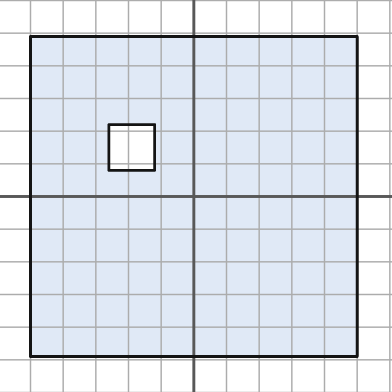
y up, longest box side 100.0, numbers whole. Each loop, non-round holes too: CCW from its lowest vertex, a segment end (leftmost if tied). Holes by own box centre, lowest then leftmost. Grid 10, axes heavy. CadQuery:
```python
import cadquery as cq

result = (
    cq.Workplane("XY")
    .moveTo(-50.0, -49.0)
    .lineTo(50.0, -49.0)
    .lineTo(50.0, 49.0)
    .lineTo(-50.0, 49.0)
    .close()
    .moveTo(-26.0, 8.0)
    .lineTo(-12.0, 8.0)
    .lineTo(-12.0, 22.0)
    .lineTo(-26.0, 22.0)
    .close()
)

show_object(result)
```